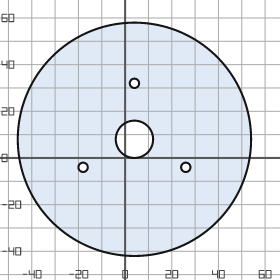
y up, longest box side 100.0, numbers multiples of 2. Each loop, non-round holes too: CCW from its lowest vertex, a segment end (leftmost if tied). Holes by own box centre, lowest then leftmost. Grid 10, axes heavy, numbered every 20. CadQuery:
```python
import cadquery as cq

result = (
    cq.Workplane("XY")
    .moveTo(4.0, 8.0)
    .circle(50.0)
    .moveTo(-18.0, -4.0)
    .circle(2.0)
    .moveTo(26.0, -4.0)
    .circle(2.0)
    .moveTo(4.0, 8.0)
    .circle(8.0)
    .moveTo(4.0, 32.0)
    .circle(2.0)
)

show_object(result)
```